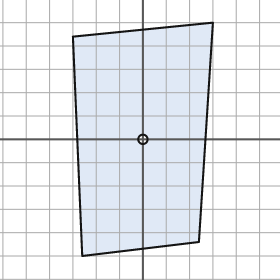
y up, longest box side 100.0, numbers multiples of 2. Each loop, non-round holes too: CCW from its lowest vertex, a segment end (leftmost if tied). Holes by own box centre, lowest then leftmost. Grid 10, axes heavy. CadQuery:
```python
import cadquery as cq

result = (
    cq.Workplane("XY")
    .moveTo(-26.0, -50.0)
    .lineTo(24.0, -44.0)
    .lineTo(30.0, 50.0)
    .lineTo(-30.0, 44.0)
    .close()
    .moveTo(0.0, 0.0)
    .circle(2.0)
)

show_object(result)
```